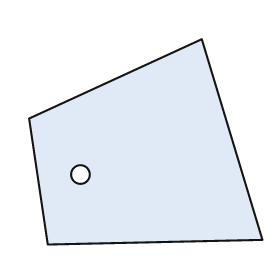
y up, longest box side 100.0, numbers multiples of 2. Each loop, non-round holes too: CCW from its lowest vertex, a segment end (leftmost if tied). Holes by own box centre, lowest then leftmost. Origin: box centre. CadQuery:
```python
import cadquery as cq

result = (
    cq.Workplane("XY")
    .moveTo(-42.0, -44.0)
    .lineTo(50.0, -42.0)
    .lineTo(24.0, 44.0)
    .lineTo(-50.0, 10.0)
    .close()
    .moveTo(-28.0, -14.0)
    .circle(4.0)
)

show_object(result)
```